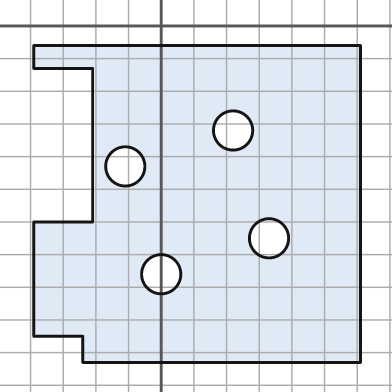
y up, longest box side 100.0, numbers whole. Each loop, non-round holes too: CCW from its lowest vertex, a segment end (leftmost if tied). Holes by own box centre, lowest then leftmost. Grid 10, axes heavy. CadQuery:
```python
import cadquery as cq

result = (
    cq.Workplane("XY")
    .moveTo(-24.0, -103.0)
    .lineTo(61.0, -103.0)
    .lineTo(61.0, -6.0)
    .lineTo(-39.0, -6.0)
    .lineTo(-39.0, -13.0)
    .lineTo(-21.0, -13.0)
    .lineTo(-21.0, -60.0)
    .lineTo(-39.0, -60.0)
    .lineTo(-39.0, -95.0)
    .lineTo(-24.0, -95.0)
    .close()
    .moveTo(0.0, -76.0)
    .circle(6.0)
    .moveTo(33.0, -65.0)
    .circle(6.0)
    .moveTo(-11.0, -43.0)
    .circle(6.0)
    .moveTo(22.0, -32.0)
    .circle(6.0)
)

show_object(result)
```